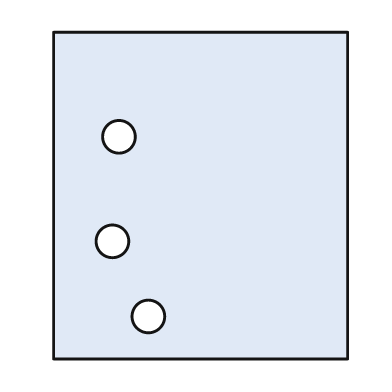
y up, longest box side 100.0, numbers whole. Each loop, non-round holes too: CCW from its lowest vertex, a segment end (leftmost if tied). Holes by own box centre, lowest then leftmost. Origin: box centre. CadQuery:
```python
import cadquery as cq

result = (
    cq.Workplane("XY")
    .moveTo(-45.0, -50.0)
    .lineTo(45.0, -50.0)
    .lineTo(45.0, 50.0)
    .lineTo(-45.0, 50.0)
    .close()
    .moveTo(-16.0, -37.0)
    .circle(5.0)
    .moveTo(-27.0, -14.0)
    .circle(5.0)
    .moveTo(-25.0, 18.0)
    .circle(5.0)
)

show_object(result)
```